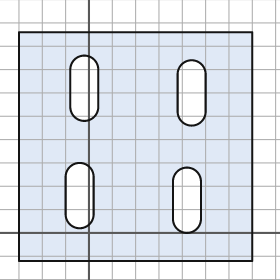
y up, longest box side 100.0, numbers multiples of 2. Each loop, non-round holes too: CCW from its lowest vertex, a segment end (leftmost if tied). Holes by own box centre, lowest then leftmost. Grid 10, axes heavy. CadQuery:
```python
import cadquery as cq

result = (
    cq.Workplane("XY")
    .moveTo(-30.0, -12.0)
    .lineTo(70.0, -12.0)
    .lineTo(70.0, 86.0)
    .lineTo(-30.0, 86.0)
    .close()
    .moveTo(36.0, 6.0)
    .threePointArc((42.0, 0.0), (48.0, 6.0))
    .lineTo(48.0, 22.0)
    .threePointArc((42.0, 28.0), (36.0, 22.0))
    .close()
    .moveTo(-10.0, 8.0)
    .threePointArc((-4.0, 2.0), (2.0, 8.0))
    .lineTo(2.0, 24.0)
    .threePointArc((-4.0, 30.0), (-10.0, 24.0))
    .close()
    .moveTo(38.0, 52.0)
    .threePointArc((44.0, 46.0), (50.0, 52.0))
    .lineTo(50.0, 68.0)
    .threePointArc((44.0, 74.0), (38.0, 68.0))
    .close()
    .moveTo(-8.0, 54.0)
    .threePointArc((-2.0, 48.0), (4.0, 54.0))
    .lineTo(4.0, 70.0)
    .threePointArc((-2.0, 76.0), (-8.0, 70.0))
    .close()
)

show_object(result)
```